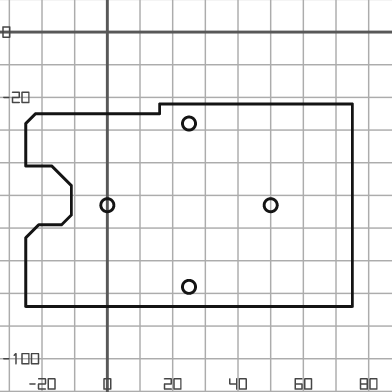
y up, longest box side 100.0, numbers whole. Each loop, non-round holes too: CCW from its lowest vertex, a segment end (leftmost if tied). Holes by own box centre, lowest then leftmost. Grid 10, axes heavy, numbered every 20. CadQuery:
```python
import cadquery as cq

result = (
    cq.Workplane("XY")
    .moveTo(-25.0, -84.0)
    .lineTo(75.0, -84.0)
    .lineTo(75.0, -22.0)
    .lineTo(16.0, -22.0)
    .lineTo(16.0, -25.0)
    .lineTo(-22.0, -25.0)
    .lineTo(-25.0, -28.0)
    .lineTo(-25.0, -41.0)
    .lineTo(-17.0, -41.0)
    .lineTo(-11.0, -47.0)
    .lineTo(-11.0, -56.0)
    .lineTo(-14.0, -59.0)
    .lineTo(-21.0, -59.0)
    .lineTo(-25.0, -63.0)
    .close()
    .moveTo(25.0, -78.0)
    .circle(2.0)
    .moveTo(0.0, -53.0)
    .circle(2.0)
    .moveTo(50.0, -53.0)
    .circle(2.0)
    .moveTo(25.0, -28.0)
    .circle(2.0)
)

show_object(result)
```